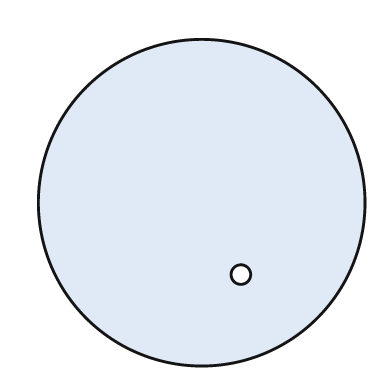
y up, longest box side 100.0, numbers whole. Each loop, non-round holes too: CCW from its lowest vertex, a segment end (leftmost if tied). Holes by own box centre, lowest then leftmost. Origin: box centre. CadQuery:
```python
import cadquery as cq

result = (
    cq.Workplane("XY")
    .moveTo(0.0, 0.0)
    .circle(50.0)
    .moveTo(12.0, -22.0)
    .circle(3.0)
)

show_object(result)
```